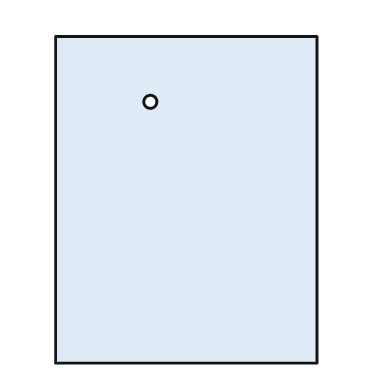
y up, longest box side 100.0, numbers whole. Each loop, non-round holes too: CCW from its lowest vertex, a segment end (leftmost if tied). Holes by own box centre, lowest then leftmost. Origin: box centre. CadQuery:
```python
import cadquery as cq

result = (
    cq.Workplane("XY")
    .moveTo(-40.0, -50.0)
    .lineTo(40.0, -50.0)
    .lineTo(40.0, 50.0)
    .lineTo(-40.0, 50.0)
    .close()
    .moveTo(-11.0, 30.0)
    .circle(2.0)
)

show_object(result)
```